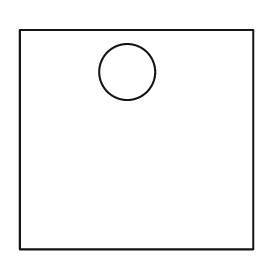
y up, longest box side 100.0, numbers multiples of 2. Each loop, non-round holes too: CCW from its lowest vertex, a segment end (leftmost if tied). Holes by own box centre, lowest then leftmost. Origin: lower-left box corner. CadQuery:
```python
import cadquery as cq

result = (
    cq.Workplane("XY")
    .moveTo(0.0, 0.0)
    .lineTo(100.0, 0.0)
    .lineTo(100.0, 94.0)
    .lineTo(0.0, 94.0)
    .close()
    .moveTo(46.0, 76.0)
    .circle(12.0)
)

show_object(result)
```